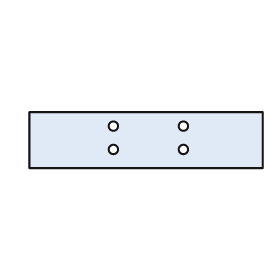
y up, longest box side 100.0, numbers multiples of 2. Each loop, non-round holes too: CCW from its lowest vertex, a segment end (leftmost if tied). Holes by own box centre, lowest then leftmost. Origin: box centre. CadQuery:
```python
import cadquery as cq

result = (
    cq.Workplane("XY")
    .moveTo(-50.0, -12.0)
    .lineTo(50.0, -12.0)
    .lineTo(50.0, 12.0)
    .lineTo(-50.0, 12.0)
    .close()
    .moveTo(-14.0, -4.0)
    .circle(2.0)
    .moveTo(16.0, -4.0)
    .circle(2.0)
    .moveTo(-14.0, 6.0)
    .circle(2.0)
    .moveTo(16.0, 6.0)
    .circle(2.0)
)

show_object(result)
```